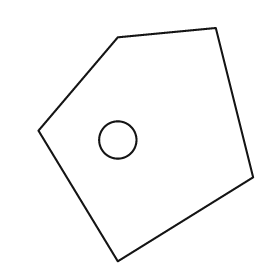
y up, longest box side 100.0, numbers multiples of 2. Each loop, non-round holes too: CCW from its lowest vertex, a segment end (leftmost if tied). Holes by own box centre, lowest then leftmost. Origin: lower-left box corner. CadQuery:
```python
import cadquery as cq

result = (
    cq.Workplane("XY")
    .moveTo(34.0, 0.0)
    .lineTo(92.0, 36.0)
    .lineTo(76.0, 100.0)
    .lineTo(34.0, 96.0)
    .lineTo(0.0, 56.0)
    .close()
    .moveTo(34.0, 52.0)
    .circle(8.0)
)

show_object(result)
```